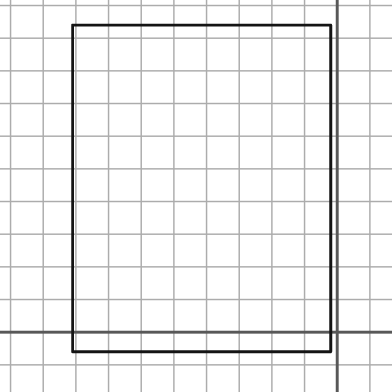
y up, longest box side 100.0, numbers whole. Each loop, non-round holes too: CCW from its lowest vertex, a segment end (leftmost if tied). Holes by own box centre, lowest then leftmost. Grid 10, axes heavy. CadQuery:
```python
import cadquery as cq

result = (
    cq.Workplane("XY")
    .moveTo(-81.0, -6.0)
    .lineTo(-2.0, -6.0)
    .lineTo(-2.0, 94.0)
    .lineTo(-81.0, 94.0)
    .close()
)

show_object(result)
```